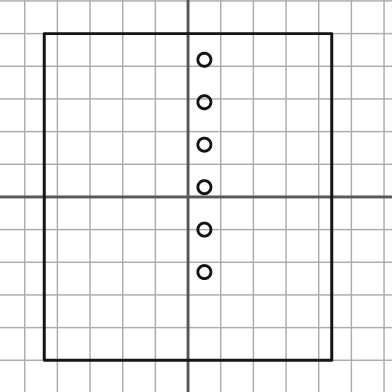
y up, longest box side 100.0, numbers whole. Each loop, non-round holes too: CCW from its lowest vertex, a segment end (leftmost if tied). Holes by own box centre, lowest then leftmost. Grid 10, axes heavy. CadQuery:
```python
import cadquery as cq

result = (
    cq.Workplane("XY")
    .moveTo(-44.0, -50.0)
    .lineTo(44.0, -50.0)
    .lineTo(44.0, 50.0)
    .lineTo(-44.0, 50.0)
    .close()
    .moveTo(5.0, -23.0)
    .circle(2.0)
    .moveTo(5.0, -10.0)
    .circle(2.0)
    .moveTo(5.0, 3.0)
    .circle(2.0)
    .moveTo(5.0, 16.0)
    .circle(2.0)
    .moveTo(5.0, 29.0)
    .circle(2.0)
    .moveTo(5.0, 42.0)
    .circle(2.0)
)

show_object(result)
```